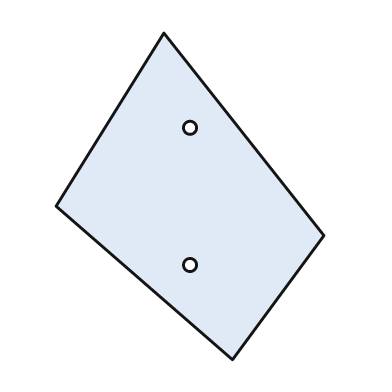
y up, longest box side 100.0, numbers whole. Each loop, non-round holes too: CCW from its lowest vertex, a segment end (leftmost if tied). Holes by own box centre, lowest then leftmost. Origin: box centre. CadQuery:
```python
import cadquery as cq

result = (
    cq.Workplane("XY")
    .moveTo(13.0, -50.0)
    .lineTo(41.0, -12.0)
    .lineTo(-8.0, 50.0)
    .lineTo(-41.0, -3.0)
    .close()
    .moveTo(0.0, -21.0)
    .circle(2.0)
    .moveTo(0.0, 21.0)
    .circle(2.0)
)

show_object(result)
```